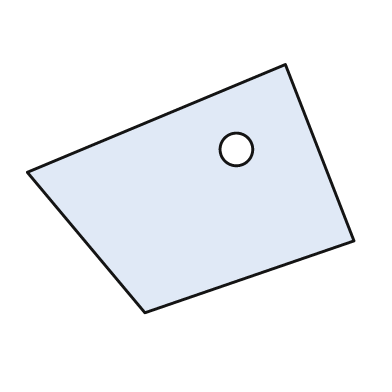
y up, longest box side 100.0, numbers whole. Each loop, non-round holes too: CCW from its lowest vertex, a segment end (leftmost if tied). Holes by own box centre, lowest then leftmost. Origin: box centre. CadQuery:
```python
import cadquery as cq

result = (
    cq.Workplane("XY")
    .moveTo(-14.0, -38.0)
    .lineTo(50.0, -16.0)
    .lineTo(29.0, 38.0)
    .lineTo(-50.0, 5.0)
    .close()
    .moveTo(14.0, 12.0)
    .circle(5.0)
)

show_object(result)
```